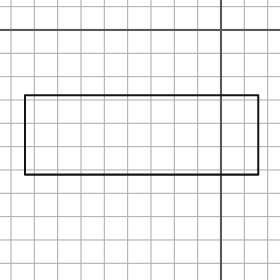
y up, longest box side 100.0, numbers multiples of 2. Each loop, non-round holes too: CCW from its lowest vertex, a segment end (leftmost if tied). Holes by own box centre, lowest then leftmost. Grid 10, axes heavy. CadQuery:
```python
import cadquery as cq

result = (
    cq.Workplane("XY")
    .moveTo(-84.0, -62.0)
    .lineTo(16.0, -62.0)
    .lineTo(16.0, -28.0)
    .lineTo(-84.0, -28.0)
    .close()
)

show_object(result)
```